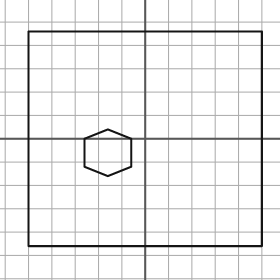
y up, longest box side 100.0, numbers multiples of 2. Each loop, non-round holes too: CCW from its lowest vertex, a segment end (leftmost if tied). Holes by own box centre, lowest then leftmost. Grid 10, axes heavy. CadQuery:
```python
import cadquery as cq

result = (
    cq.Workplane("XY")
    .moveTo(-50.0, -46.0)
    .lineTo(50.0, -46.0)
    .lineTo(50.0, 46.0)
    .lineTo(-50.0, 46.0)
    .close()
    .moveTo(-16.0, -16.0)
    .lineTo(-6.0, -12.0)
    .lineTo(-6.0, 0.0)
    .lineTo(-16.0, 4.0)
    .lineTo(-26.0, 0.0)
    .lineTo(-26.0, -12.0)
    .close()
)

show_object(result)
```